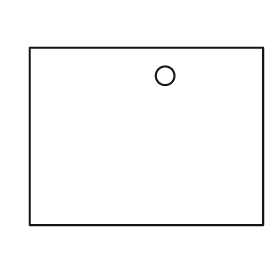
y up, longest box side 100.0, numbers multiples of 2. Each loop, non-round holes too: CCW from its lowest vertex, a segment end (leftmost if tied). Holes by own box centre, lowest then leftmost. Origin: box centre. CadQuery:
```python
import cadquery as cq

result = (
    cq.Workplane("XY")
    .moveTo(-50.0, -38.0)
    .lineTo(50.0, -38.0)
    .lineTo(50.0, 38.0)
    .lineTo(-50.0, 38.0)
    .close()
    .moveTo(8.0, 26.0)
    .circle(4.0)
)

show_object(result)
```